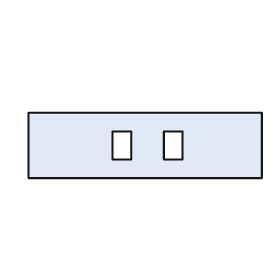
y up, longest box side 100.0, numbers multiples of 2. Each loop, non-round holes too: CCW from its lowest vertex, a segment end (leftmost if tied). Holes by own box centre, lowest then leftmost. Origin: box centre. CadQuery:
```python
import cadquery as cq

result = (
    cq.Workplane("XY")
    .moveTo(-50.0, -14.0)
    .lineTo(50.0, -14.0)
    .lineTo(50.0, 14.0)
    .lineTo(-50.0, 14.0)
    .close()
    .moveTo(-14.0, -6.0)
    .lineTo(-6.0, -6.0)
    .lineTo(-6.0, 6.0)
    .lineTo(-14.0, 6.0)
    .close()
    .moveTo(8.0, -6.0)
    .lineTo(16.0, -6.0)
    .lineTo(16.0, 6.0)
    .lineTo(8.0, 6.0)
    .close()
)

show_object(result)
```